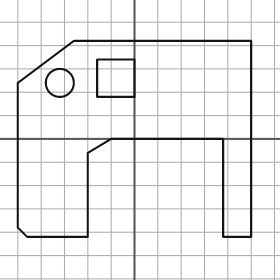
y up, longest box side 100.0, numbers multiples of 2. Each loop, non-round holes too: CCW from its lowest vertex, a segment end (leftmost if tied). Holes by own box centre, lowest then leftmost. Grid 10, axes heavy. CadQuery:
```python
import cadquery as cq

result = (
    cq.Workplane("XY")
    .moveTo(-46.0, -42.0)
    .lineTo(-20.0, -42.0)
    .lineTo(-20.0, -6.0)
    .lineTo(-10.0, 0.0)
    .lineTo(38.0, 0.0)
    .lineTo(38.0, -42.0)
    .lineTo(50.0, -42.0)
    .lineTo(50.0, 42.0)
    .lineTo(-26.0, 42.0)
    .lineTo(-50.0, 24.0)
    .lineTo(-50.0, -38.0)
    .close()
    .moveTo(-32.0, 24.0)
    .circle(6.0)
    .moveTo(-16.0, 18.0)
    .lineTo(0.0, 18.0)
    .lineTo(0.0, 34.0)
    .lineTo(-16.0, 34.0)
    .close()
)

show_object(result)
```